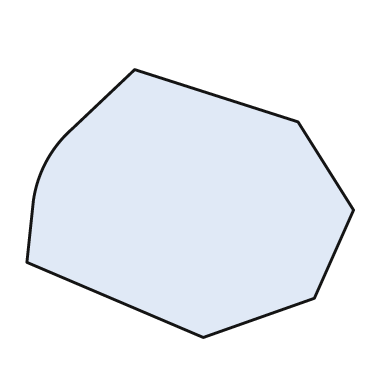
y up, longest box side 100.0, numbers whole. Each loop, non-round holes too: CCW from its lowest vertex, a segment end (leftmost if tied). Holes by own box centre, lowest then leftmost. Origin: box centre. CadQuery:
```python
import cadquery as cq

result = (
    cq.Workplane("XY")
    .moveTo(4.0, -41.0)
    .lineTo(38.0, -29.0)
    .lineTo(50.0, -2.0)
    .lineTo(33.0, 25.0)
    .lineTo(-17.0, 41.0)
    .lineTo(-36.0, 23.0)
    .threePointArc((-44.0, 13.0), (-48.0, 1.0))
    .lineTo(-50.0, -18.0)
    .close()
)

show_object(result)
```